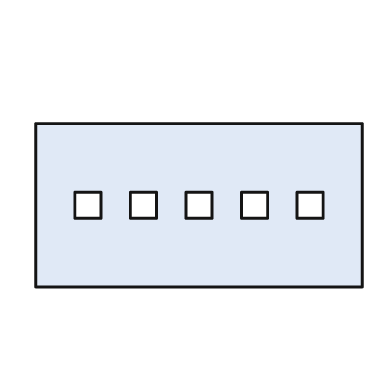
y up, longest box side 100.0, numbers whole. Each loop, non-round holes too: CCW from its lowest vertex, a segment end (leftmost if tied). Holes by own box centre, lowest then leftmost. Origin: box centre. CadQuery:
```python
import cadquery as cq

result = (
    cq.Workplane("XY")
    .moveTo(-50.0, -25.0)
    .lineTo(50.0, -25.0)
    .lineTo(50.0, 25.0)
    .lineTo(-50.0, 25.0)
    .close()
    .moveTo(-38.0, -4.0)
    .lineTo(-30.0, -4.0)
    .lineTo(-30.0, 4.0)
    .lineTo(-38.0, 4.0)
    .close()
    .moveTo(-21.0, -4.0)
    .lineTo(-13.0, -4.0)
    .lineTo(-13.0, 4.0)
    .lineTo(-21.0, 4.0)
    .close()
    .moveTo(-4.0, -4.0)
    .lineTo(4.0, -4.0)
    .lineTo(4.0, 4.0)
    .lineTo(-4.0, 4.0)
    .close()
    .moveTo(13.0, -4.0)
    .lineTo(21.0, -4.0)
    .lineTo(21.0, 4.0)
    .lineTo(13.0, 4.0)
    .close()
    .moveTo(30.0, -4.0)
    .lineTo(38.0, -4.0)
    .lineTo(38.0, 4.0)
    .lineTo(30.0, 4.0)
    .close()
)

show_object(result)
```